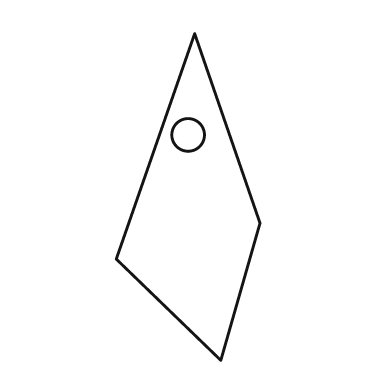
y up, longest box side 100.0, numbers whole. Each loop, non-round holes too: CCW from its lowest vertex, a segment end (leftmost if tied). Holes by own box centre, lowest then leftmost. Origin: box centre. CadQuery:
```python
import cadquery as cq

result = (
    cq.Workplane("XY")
    .moveTo(10.0, -50.0)
    .lineTo(22.0, -8.0)
    .lineTo(2.0, 50.0)
    .lineTo(-22.0, -19.0)
    .close()
    .moveTo(0.0, 19.0)
    .circle(5.0)
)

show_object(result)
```